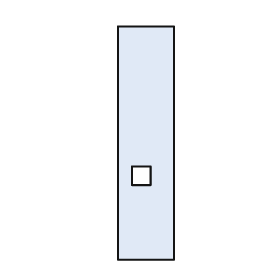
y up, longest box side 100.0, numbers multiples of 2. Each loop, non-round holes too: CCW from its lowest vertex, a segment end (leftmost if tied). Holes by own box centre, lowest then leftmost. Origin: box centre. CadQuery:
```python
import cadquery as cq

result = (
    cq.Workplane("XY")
    .moveTo(-12.0, -50.0)
    .lineTo(12.0, -50.0)
    .lineTo(12.0, 50.0)
    .lineTo(-12.0, 50.0)
    .close()
    .moveTo(-6.0, -18.0)
    .lineTo(2.0, -18.0)
    .lineTo(2.0, -10.0)
    .lineTo(-6.0, -10.0)
    .close()
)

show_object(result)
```